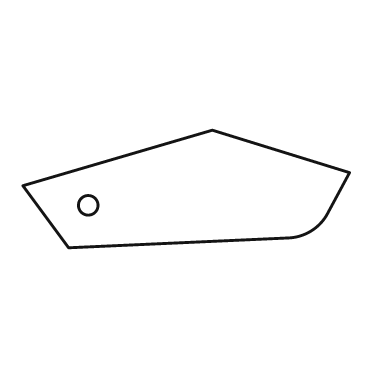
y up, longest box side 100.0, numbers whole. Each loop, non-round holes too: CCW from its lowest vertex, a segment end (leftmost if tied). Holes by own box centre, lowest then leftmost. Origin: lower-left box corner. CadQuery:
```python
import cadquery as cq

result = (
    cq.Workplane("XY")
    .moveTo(14.0, 0.0)
    .lineTo(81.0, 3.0)
    .threePointArc((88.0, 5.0), (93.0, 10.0))
    .lineTo(100.0, 23.0)
    .lineTo(58.0, 36.0)
    .lineTo(0.0, 19.0)
    .close()
    .moveTo(20.0, 13.0)
    .circle(3.0)
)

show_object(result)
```